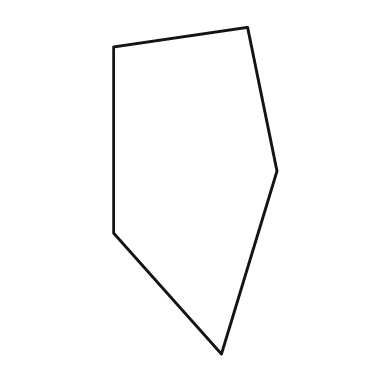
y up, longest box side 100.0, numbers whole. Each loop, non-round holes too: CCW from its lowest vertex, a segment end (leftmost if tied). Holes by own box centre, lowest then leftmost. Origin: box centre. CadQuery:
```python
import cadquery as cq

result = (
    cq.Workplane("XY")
    .moveTo(8.0, -50.0)
    .lineTo(25.0, 6.0)
    .lineTo(16.0, 50.0)
    .lineTo(-25.0, 44.0)
    .lineTo(-25.0, -13.0)
    .close()
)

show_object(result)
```